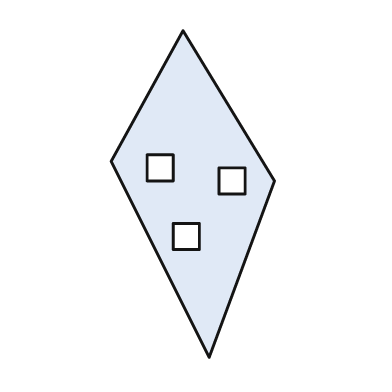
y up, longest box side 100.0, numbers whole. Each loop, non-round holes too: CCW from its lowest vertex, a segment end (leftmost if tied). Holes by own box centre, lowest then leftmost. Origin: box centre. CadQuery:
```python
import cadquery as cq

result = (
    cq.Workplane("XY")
    .moveTo(5.0, -50.0)
    .lineTo(25.0, 4.0)
    .lineTo(-3.0, 50.0)
    .lineTo(-25.0, 10.0)
    .close()
    .moveTo(-6.0, -17.0)
    .lineTo(2.0, -17.0)
    .lineTo(2.0, -9.0)
    .lineTo(-6.0, -9.0)
    .close()
    .moveTo(8.0, 0.0)
    .lineTo(16.0, 0.0)
    .lineTo(16.0, 8.0)
    .lineTo(8.0, 8.0)
    .close()
    .moveTo(-14.0, 4.0)
    .lineTo(-6.0, 4.0)
    .lineTo(-6.0, 12.0)
    .lineTo(-14.0, 12.0)
    .close()
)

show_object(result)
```